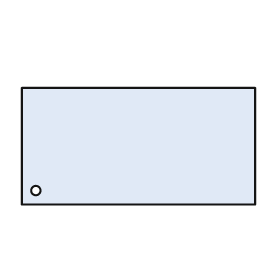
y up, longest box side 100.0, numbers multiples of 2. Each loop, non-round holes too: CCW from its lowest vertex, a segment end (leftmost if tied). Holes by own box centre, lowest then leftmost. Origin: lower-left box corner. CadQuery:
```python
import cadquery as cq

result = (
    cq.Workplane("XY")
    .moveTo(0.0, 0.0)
    .lineTo(100.0, 0.0)
    .lineTo(100.0, 50.0)
    .lineTo(0.0, 50.0)
    .close()
    .moveTo(6.0, 6.0)
    .circle(2.0)
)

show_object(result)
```